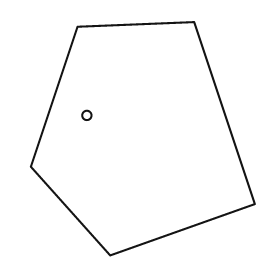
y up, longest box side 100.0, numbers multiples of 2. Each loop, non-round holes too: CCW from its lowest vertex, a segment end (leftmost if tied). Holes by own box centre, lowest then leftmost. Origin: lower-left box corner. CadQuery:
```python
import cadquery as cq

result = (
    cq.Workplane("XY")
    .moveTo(34.0, 0.0)
    .lineTo(96.0, 22.0)
    .lineTo(70.0, 100.0)
    .lineTo(20.0, 98.0)
    .lineTo(0.0, 38.0)
    .close()
    .moveTo(24.0, 60.0)
    .circle(2.0)
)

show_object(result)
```